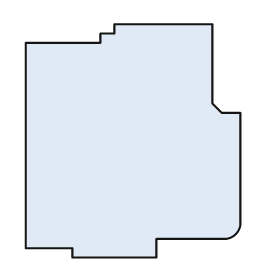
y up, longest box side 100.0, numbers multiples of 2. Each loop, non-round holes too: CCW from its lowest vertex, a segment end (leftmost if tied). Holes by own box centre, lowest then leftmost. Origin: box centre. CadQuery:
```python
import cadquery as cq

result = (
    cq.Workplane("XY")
    .moveTo(-26.0, -50.0)
    .lineTo(10.0, -50.0)
    .lineTo(10.0, -42.0)
    .lineTo(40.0, -42.0)
    .threePointArc((44.0, -40.0), (46.0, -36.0))
    .lineTo(46.0, 12.0)
    .lineTo(38.0, 12.0)
    .lineTo(34.0, 16.0)
    .lineTo(34.0, 50.0)
    .lineTo(-8.0, 50.0)
    .lineTo(-8.0, 46.0)
    .lineTo(-14.0, 46.0)
    .lineTo(-14.0, 42.0)
    .lineTo(-46.0, 42.0)
    .lineTo(-46.0, -46.0)
    .lineTo(-26.0, -46.0)
    .close()
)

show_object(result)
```